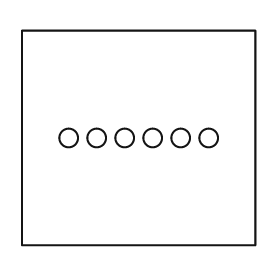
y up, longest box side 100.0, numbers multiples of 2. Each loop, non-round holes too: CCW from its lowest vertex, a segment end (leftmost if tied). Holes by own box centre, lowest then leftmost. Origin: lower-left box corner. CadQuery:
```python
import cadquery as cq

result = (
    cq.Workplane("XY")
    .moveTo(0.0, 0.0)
    .lineTo(100.0, 0.0)
    .lineTo(100.0, 92.0)
    .lineTo(0.0, 92.0)
    .close()
    .moveTo(20.0, 46.0)
    .circle(4.0)
    .moveTo(32.0, 46.0)
    .circle(4.0)
    .moveTo(44.0, 46.0)
    .circle(4.0)
    .moveTo(56.0, 46.0)
    .circle(4.0)
    .moveTo(68.0, 46.0)
    .circle(4.0)
    .moveTo(80.0, 46.0)
    .circle(4.0)
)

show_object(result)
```